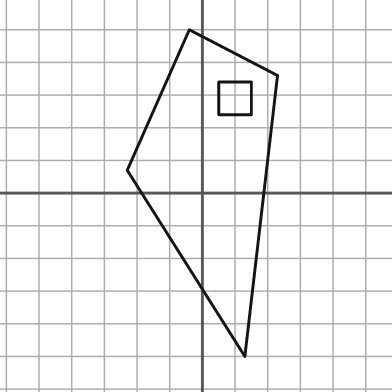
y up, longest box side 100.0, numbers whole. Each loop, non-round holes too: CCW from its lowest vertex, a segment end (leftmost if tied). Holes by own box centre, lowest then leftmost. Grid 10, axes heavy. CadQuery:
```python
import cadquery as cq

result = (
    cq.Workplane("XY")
    .moveTo(13.0, -50.0)
    .lineTo(23.0, 36.0)
    .lineTo(-4.0, 50.0)
    .lineTo(-23.0, 7.0)
    .close()
    .moveTo(5.0, 24.0)
    .lineTo(15.0, 24.0)
    .lineTo(15.0, 34.0)
    .lineTo(5.0, 34.0)
    .close()
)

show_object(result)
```